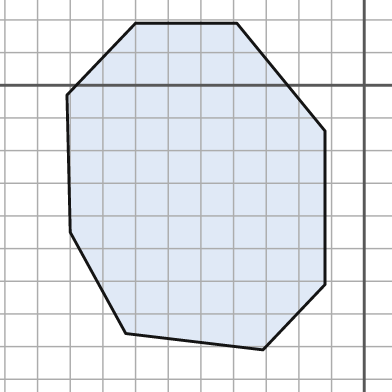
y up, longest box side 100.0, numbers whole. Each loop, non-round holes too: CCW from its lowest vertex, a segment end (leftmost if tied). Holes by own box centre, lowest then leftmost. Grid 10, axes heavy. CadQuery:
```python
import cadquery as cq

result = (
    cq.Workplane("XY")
    .moveTo(-31.0, -81.0)
    .lineTo(-12.0, -61.0)
    .lineTo(-12.0, -14.0)
    .lineTo(-39.0, 19.0)
    .lineTo(-70.0, 19.0)
    .lineTo(-91.0, -3.0)
    .lineTo(-90.0, -45.0)
    .lineTo(-73.0, -76.0)
    .close()
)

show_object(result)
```